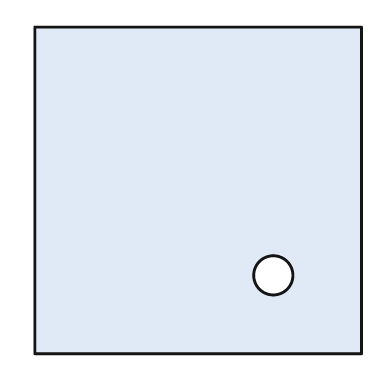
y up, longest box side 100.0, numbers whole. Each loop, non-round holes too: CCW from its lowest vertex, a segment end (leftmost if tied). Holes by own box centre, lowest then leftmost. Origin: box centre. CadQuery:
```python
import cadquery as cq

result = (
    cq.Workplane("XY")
    .moveTo(-50.0, -50.0)
    .lineTo(50.0, -50.0)
    .lineTo(50.0, 50.0)
    .lineTo(-50.0, 50.0)
    .close()
    .moveTo(23.0, -26.0)
    .circle(6.0)
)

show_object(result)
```